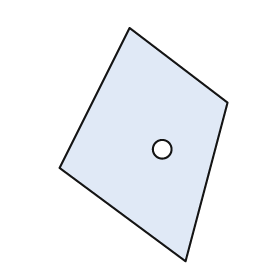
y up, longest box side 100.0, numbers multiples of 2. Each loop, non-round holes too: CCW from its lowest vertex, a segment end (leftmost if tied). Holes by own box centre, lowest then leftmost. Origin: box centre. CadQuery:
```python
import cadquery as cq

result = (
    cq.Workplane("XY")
    .moveTo(18.0, -50.0)
    .lineTo(36.0, 18.0)
    .lineTo(-6.0, 50.0)
    .lineTo(-36.0, -10.0)
    .close()
    .moveTo(8.0, -2.0)
    .circle(4.0)
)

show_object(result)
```